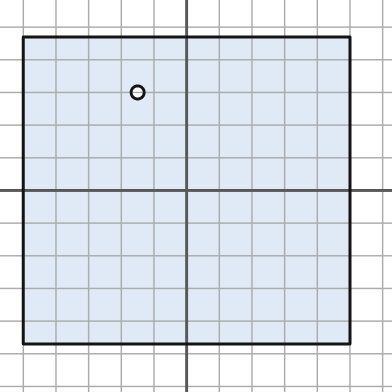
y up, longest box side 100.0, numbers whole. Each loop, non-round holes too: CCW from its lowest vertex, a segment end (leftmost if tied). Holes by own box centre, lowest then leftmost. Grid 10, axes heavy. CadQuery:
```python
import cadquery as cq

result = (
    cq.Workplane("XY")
    .moveTo(-50.0, -47.0)
    .lineTo(50.0, -47.0)
    .lineTo(50.0, 47.0)
    .lineTo(-50.0, 47.0)
    .close()
    .moveTo(-15.0, 30.0)
    .circle(2.0)
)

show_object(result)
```